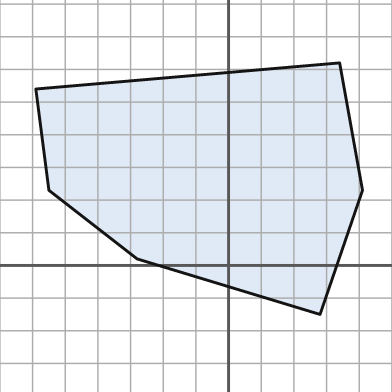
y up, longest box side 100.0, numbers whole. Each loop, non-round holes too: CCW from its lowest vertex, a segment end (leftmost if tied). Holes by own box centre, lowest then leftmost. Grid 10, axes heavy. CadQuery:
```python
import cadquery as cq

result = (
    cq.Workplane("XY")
    .moveTo(28.0, -15.0)
    .lineTo(41.0, 23.0)
    .lineTo(34.0, 62.0)
    .lineTo(-59.0, 54.0)
    .lineTo(-55.0, 23.0)
    .lineTo(-28.0, 2.0)
    .close()
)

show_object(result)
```